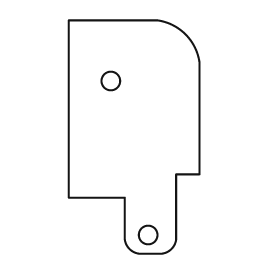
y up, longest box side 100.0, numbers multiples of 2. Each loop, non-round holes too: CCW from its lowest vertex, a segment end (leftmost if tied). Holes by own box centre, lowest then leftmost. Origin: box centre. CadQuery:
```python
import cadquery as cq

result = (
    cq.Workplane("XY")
    .moveTo(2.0, -50.0)
    .lineTo(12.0, -50.0)
    .threePointArc((16.0, -48.0), (18.0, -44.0))
    .lineTo(18.0, -16.0)
    .lineTo(28.0, -16.0)
    .lineTo(28.0, 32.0)
    .threePointArc((22.0, 44.0), (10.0, 50.0))
    .lineTo(-28.0, 50.0)
    .lineTo(-28.0, -26.0)
    .lineTo(-4.0, -26.0)
    .lineTo(-4.0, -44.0)
    .threePointArc((-2.0, -48.0), (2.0, -50.0))
    .close()
    .moveTo(6.0, -42.0)
    .circle(4.0)
    .moveTo(-10.0, 24.0)
    .circle(4.0)
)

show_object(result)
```